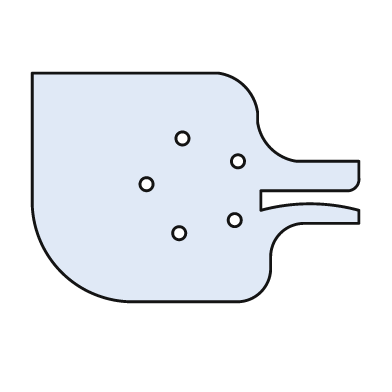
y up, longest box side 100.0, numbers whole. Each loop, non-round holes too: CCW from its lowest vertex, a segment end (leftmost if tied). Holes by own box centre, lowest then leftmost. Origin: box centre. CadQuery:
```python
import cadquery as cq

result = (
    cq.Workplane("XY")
    .moveTo(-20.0, -35.0)
    .lineTo(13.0, -35.0)
    .threePointArc((20.0, -32.0), (23.0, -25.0))
    .lineTo(23.0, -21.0)
    .threePointArc((26.0, -14.0), (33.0, -11.0))
    .lineTo(50.0, -11.0)
    .lineTo(50.0, -7.0)
    .threePointArc((35.0, -5.0), (20.0, -7.0))
    .lineTo(20.0, -1.0)
    .lineTo(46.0, -1.0)
    .threePointArc((49.0, 0.0), (50.0, 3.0))
    .lineTo(50.0, 8.0)
    .lineTo(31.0, 8.0)
    .threePointArc((23.0, 12.0), (19.0, 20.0))
    .lineTo(19.0, 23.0)
    .threePointArc((15.0, 31.0), (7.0, 35.0))
    .lineTo(-50.0, 35.0)
    .lineTo(-50.0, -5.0)
    .threePointArc((-41.0, -26.0), (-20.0, -35.0))
    .close()
    .moveTo(-5.0, -14.0)
    .circle(2.0)
    .moveTo(12.0, -10.0)
    .circle(2.0)
    .moveTo(-15.0, 1.0)
    .circle(2.0)
    .moveTo(13.0, 8.0)
    .circle(2.0)
    .moveTo(-4.0, 15.0)
    .circle(2.0)
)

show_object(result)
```